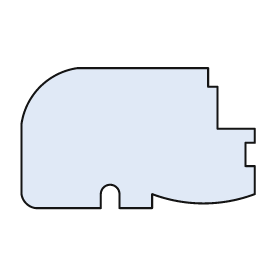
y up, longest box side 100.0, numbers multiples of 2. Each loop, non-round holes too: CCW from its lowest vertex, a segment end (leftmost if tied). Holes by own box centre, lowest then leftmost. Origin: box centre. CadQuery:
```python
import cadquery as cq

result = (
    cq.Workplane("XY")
    .moveTo(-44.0, -30.0)
    .lineTo(-16.0, -30.0)
    .lineTo(-16.0, -24.0)
    .threePointArc((-12.0, -20.0), (-8.0, -24.0))
    .lineTo(-8.0, -30.0)
    .lineTo(6.0, -30.0)
    .lineTo(6.0, -24.0)
    .threePointArc((28.0, -28.0), (50.0, -24.0))
    .lineTo(50.0, -12.0)
    .lineTo(46.0, -12.0)
    .lineTo(46.0, -2.0)
    .lineTo(50.0, -2.0)
    .lineTo(50.0, 4.0)
    .lineTo(34.0, 4.0)
    .lineTo(34.0, 22.0)
    .lineTo(30.0, 22.0)
    .lineTo(30.0, 30.0)
    .lineTo(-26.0, 30.0)
    .threePointArc((-42.0, 22.0), (-50.0, 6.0))
    .lineTo(-50.0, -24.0)
    .threePointArc((-48.0, -28.0), (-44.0, -30.0))
    .close()
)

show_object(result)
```